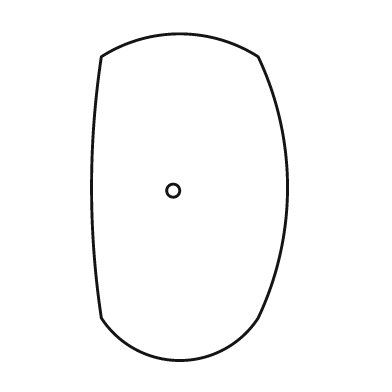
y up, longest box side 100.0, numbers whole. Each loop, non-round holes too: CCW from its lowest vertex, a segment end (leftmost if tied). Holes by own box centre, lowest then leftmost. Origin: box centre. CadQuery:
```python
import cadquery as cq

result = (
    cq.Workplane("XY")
    .moveTo(-27.0, -37.0)
    .threePointArc((-3.0, -50.0), (21.0, -37.0))
    .threePointArc((30.0, 3.0), (21.0, 43.0))
    .threePointArc((-3.0, 50.0), (-27.0, 43.0))
    .threePointArc((-30.0, 3.0), (-27.0, -37.0))
    .close()
    .moveTo(-5.0, 2.0)
    .circle(2.0)
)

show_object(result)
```